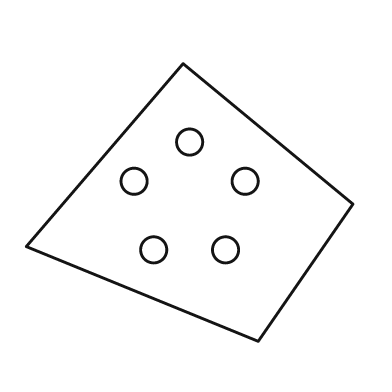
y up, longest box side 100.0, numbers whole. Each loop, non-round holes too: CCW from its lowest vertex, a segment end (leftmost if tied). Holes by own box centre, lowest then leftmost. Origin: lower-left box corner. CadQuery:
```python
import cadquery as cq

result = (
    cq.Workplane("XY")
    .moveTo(71.0, 0.0)
    .lineTo(100.0, 42.0)
    .lineTo(48.0, 85.0)
    .lineTo(0.0, 29.0)
    .close()
    .moveTo(39.0, 28.0)
    .circle(4.0)
    .moveTo(61.0, 28.0)
    .circle(4.0)
    .moveTo(33.0, 49.0)
    .circle(4.0)
    .moveTo(67.0, 49.0)
    .circle(4.0)
    .moveTo(50.0, 61.0)
    .circle(4.0)
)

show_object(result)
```